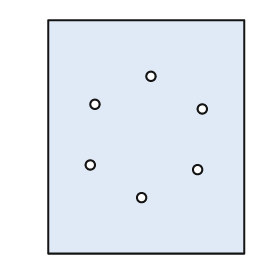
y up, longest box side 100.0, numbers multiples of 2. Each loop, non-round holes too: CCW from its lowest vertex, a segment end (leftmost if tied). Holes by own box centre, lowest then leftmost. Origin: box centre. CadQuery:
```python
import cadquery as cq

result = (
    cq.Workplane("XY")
    .moveTo(-42.0, -50.0)
    .lineTo(42.0, -50.0)
    .lineTo(42.0, 50.0)
    .lineTo(-42.0, 50.0)
    .close()
    .moveTo(-2.0, -26.0)
    .circle(2.0)
    .moveTo(22.0, -14.0)
    .circle(2.0)
    .moveTo(-24.0, -12.0)
    .circle(2.0)
    .moveTo(24.0, 12.0)
    .circle(2.0)
    .moveTo(-22.0, 14.0)
    .circle(2.0)
    .moveTo(2.0, 26.0)
    .circle(2.0)
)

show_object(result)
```